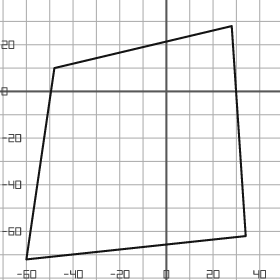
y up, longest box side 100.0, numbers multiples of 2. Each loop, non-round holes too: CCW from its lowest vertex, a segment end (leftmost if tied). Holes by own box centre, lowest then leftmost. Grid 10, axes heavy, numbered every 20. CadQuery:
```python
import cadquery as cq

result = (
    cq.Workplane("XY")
    .moveTo(-60.0, -72.0)
    .lineTo(34.0, -62.0)
    .lineTo(28.0, 28.0)
    .lineTo(-48.0, 10.0)
    .close()
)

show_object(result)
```